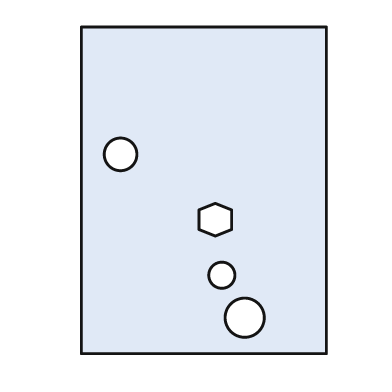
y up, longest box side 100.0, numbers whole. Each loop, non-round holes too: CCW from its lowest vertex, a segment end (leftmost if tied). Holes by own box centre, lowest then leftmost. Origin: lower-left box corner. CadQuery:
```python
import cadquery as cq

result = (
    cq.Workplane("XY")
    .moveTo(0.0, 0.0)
    .lineTo(75.0, 0.0)
    .lineTo(75.0, 100.0)
    .lineTo(0.0, 100.0)
    .close()
    .moveTo(50.0, 11.0)
    .circle(6.0)
    .moveTo(43.0, 24.0)
    .circle(4.0)
    .moveTo(41.0, 36.0)
    .lineTo(46.0, 38.0)
    .lineTo(46.0, 44.0)
    .lineTo(41.0, 46.0)
    .lineTo(36.0, 44.0)
    .lineTo(36.0, 38.0)
    .close()
    .moveTo(12.0, 61.0)
    .circle(5.0)
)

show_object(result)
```